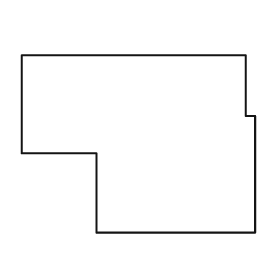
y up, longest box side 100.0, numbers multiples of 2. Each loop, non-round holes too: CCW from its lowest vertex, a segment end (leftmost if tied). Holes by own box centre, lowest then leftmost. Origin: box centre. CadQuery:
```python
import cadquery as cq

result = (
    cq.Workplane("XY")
    .moveTo(-18.0, -38.0)
    .lineTo(50.0, -38.0)
    .lineTo(50.0, 12.0)
    .lineTo(46.0, 12.0)
    .lineTo(46.0, 38.0)
    .lineTo(-50.0, 38.0)
    .lineTo(-50.0, -4.0)
    .lineTo(-18.0, -4.0)
    .close()
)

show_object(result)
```